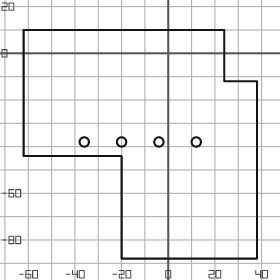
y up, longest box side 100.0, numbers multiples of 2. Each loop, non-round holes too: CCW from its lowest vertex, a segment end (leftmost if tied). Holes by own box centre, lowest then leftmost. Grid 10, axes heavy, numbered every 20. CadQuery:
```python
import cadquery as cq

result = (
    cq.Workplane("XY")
    .moveTo(-20.0, -88.0)
    .lineTo(38.0, -88.0)
    .lineTo(38.0, -12.0)
    .lineTo(24.0, -12.0)
    .lineTo(24.0, 10.0)
    .lineTo(-62.0, 10.0)
    .lineTo(-62.0, -44.0)
    .lineTo(-20.0, -44.0)
    .close()
    .moveTo(-36.0, -38.0)
    .circle(2.0)
    .moveTo(-20.0, -38.0)
    .circle(2.0)
    .moveTo(-4.0, -38.0)
    .circle(2.0)
    .moveTo(12.0, -38.0)
    .circle(2.0)
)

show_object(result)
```